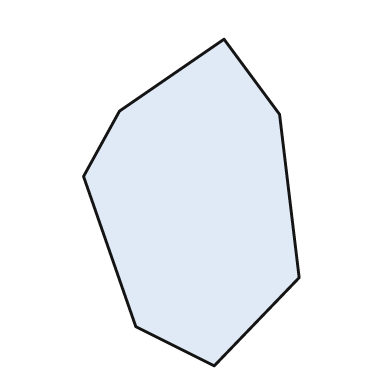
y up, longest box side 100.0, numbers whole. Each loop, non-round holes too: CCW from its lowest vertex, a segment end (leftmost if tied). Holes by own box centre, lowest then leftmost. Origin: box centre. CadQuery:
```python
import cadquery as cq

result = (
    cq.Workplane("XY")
    .moveTo(7.0, -50.0)
    .lineTo(33.0, -23.0)
    .lineTo(27.0, 27.0)
    .lineTo(10.0, 50.0)
    .lineTo(-22.0, 28.0)
    .lineTo(-33.0, 8.0)
    .lineTo(-17.0, -38.0)
    .close()
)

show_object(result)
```